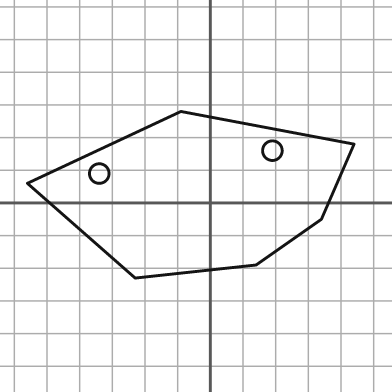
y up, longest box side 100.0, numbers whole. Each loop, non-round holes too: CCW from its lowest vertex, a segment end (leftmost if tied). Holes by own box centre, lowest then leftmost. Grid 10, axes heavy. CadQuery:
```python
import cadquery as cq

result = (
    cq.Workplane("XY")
    .moveTo(-23.0, -23.0)
    .lineTo(14.0, -19.0)
    .lineTo(34.0, -5.0)
    .lineTo(44.0, 18.0)
    .lineTo(-9.0, 28.0)
    .lineTo(-56.0, 6.0)
    .close()
    .moveTo(-34.0, 9.0)
    .circle(3.0)
    .moveTo(19.0, 16.0)
    .circle(3.0)
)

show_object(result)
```